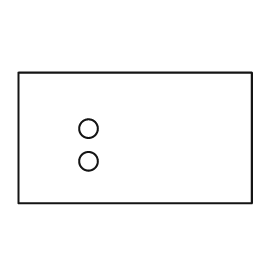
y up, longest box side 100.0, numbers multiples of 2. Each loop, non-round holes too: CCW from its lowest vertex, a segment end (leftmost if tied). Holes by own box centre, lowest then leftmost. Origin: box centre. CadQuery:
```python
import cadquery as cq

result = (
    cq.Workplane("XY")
    .moveTo(-50.0, -28.0)
    .lineTo(50.0, -28.0)
    .lineTo(50.0, 28.0)
    .lineTo(-50.0, 28.0)
    .close()
    .moveTo(-20.0, -10.0)
    .circle(4.0)
    .moveTo(-20.0, 4.0)
    .circle(4.0)
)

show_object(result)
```